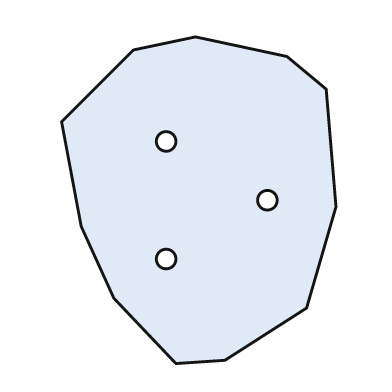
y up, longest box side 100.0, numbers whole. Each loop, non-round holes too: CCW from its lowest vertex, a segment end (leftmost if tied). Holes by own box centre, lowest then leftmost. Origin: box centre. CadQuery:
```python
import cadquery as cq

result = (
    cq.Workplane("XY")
    .moveTo(-7.0, -50.0)
    .lineTo(8.0, -49.0)
    .lineTo(33.0, -33.0)
    .lineTo(42.0, -2.0)
    .lineTo(39.0, 34.0)
    .lineTo(27.0, 44.0)
    .lineTo(-1.0, 50.0)
    .lineTo(-20.0, 46.0)
    .lineTo(-42.0, 24.0)
    .lineTo(-36.0, -8.0)
    .lineTo(-26.0, -30.0)
    .close()
    .moveTo(-10.0, -18.0)
    .circle(3.0)
    .moveTo(21.0, 0.0)
    .circle(3.0)
    .moveTo(-10.0, 18.0)
    .circle(3.0)
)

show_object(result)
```